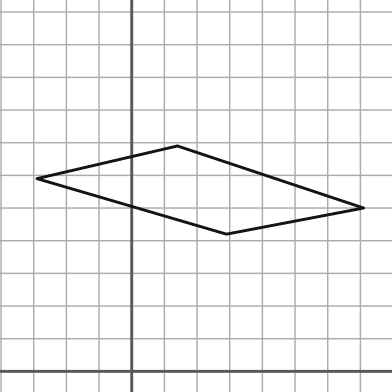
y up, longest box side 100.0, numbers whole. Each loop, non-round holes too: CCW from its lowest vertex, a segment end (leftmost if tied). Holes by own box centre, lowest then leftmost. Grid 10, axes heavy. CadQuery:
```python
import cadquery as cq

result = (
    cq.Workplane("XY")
    .moveTo(29.0, 42.0)
    .lineTo(71.0, 50.0)
    .lineTo(14.0, 69.0)
    .lineTo(-29.0, 59.0)
    .close()
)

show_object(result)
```